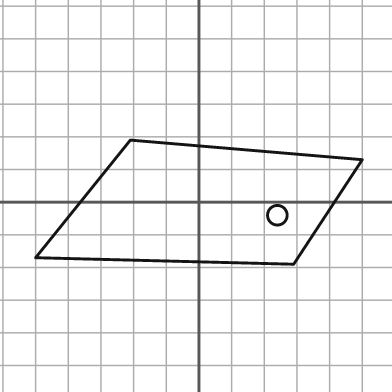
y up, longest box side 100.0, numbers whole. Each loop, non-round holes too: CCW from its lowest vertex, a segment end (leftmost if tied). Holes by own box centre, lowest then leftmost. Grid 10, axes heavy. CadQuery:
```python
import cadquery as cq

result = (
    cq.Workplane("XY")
    .moveTo(29.0, -19.0)
    .lineTo(50.0, 13.0)
    .lineTo(-21.0, 19.0)
    .lineTo(-50.0, -17.0)
    .close()
    .moveTo(24.0, -4.0)
    .circle(3.0)
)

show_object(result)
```